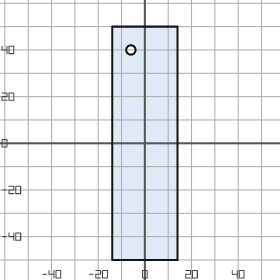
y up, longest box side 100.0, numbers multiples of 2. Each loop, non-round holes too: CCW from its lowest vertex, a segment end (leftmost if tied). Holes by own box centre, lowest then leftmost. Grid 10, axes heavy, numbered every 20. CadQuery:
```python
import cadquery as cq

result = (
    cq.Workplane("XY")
    .moveTo(-14.0, -50.0)
    .lineTo(14.0, -50.0)
    .lineTo(14.0, 50.0)
    .lineTo(-14.0, 50.0)
    .close()
    .moveTo(-6.0, 40.0)
    .circle(2.0)
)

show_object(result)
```